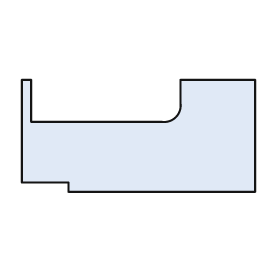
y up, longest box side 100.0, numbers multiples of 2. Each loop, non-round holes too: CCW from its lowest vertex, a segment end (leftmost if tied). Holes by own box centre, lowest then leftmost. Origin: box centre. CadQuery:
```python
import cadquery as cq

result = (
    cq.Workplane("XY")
    .moveTo(-30.0, -24.0)
    .lineTo(50.0, -24.0)
    .lineTo(50.0, 24.0)
    .lineTo(18.0, 24.0)
    .lineTo(18.0, 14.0)
    .threePointArc((16.0, 8.0), (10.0, 6.0))
    .lineTo(-46.0, 6.0)
    .lineTo(-46.0, 24.0)
    .lineTo(-50.0, 24.0)
    .lineTo(-50.0, -20.0)
    .lineTo(-30.0, -20.0)
    .close()
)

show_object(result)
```